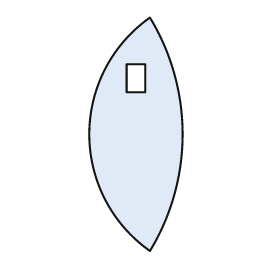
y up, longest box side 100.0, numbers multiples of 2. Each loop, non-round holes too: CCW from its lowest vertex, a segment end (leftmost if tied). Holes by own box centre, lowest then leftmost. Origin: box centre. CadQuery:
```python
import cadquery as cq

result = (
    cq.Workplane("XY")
    .moveTo(6.0, -50.0)
    .threePointArc((20.0, 0.0), (6.0, 50.0))
    .threePointArc((-20.0, 0.0), (6.0, -50.0))
    .close()
    .moveTo(-4.0, 18.0)
    .lineTo(4.0, 18.0)
    .lineTo(4.0, 30.0)
    .lineTo(-4.0, 30.0)
    .close()
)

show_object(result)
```